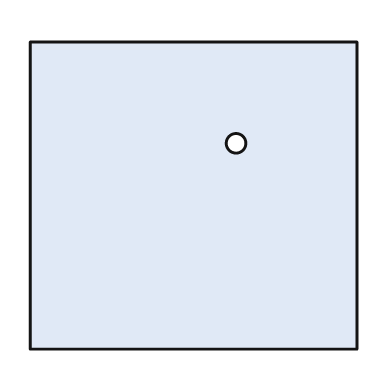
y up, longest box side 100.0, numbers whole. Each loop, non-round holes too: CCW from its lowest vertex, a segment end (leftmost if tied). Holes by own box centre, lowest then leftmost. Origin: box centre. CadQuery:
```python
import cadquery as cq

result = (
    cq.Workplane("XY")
    .moveTo(-50.0, -47.0)
    .lineTo(50.0, -47.0)
    .lineTo(50.0, 47.0)
    .lineTo(-50.0, 47.0)
    .close()
    .moveTo(13.0, 16.0)
    .circle(3.0)
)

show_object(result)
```